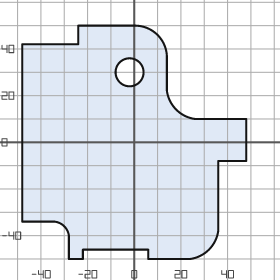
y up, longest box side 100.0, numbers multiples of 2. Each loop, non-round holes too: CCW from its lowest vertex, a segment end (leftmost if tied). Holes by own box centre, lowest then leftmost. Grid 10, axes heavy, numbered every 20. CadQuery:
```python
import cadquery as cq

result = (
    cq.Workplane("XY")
    .moveTo(-28.0, -50.0)
    .lineTo(-22.0, -50.0)
    .lineTo(-22.0, -46.0)
    .lineTo(6.0, -46.0)
    .lineTo(6.0, -50.0)
    .lineTo(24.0, -50.0)
    .threePointArc((32.0, -46.0), (36.0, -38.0))
    .lineTo(36.0, -8.0)
    .lineTo(48.0, -8.0)
    .lineTo(48.0, 10.0)
    .lineTo(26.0, 10.0)
    .threePointArc((18.0, 14.0), (14.0, 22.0))
    .lineTo(14.0, 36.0)
    .threePointArc((10.0, 46.0), (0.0, 50.0))
    .lineTo(-24.0, 50.0)
    .lineTo(-24.0, 42.0)
    .lineTo(-48.0, 42.0)
    .lineTo(-48.0, -34.0)
    .lineTo(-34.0, -34.0)
    .threePointArc((-30.0, -36.0), (-28.0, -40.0))
    .close()
    .moveTo(-2.0, 30.0)
    .circle(6.0)
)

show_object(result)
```